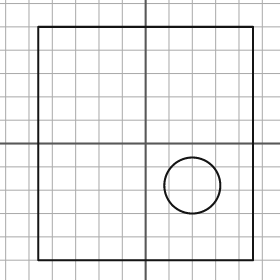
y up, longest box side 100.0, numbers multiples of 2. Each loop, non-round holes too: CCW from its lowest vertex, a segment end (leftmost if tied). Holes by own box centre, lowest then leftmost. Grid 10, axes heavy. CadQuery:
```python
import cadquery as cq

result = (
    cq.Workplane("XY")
    .moveTo(-46.0, -50.0)
    .lineTo(46.0, -50.0)
    .lineTo(46.0, 50.0)
    .lineTo(-46.0, 50.0)
    .close()
    .moveTo(20.0, -18.0)
    .circle(12.0)
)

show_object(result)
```